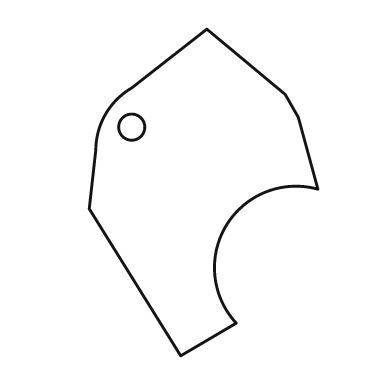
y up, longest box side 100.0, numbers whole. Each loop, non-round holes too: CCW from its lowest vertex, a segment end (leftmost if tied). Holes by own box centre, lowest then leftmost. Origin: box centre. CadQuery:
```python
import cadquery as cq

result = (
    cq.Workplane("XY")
    .moveTo(-7.0, -50.0)
    .lineTo(10.0, -40.0)
    .threePointArc((7.0, -10.0), (35.0, 1.0))
    .lineTo(29.0, 23.0)
    .lineTo(25.0, 30.0)
    .lineTo(1.0, 50.0)
    .lineTo(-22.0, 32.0)
    .threePointArc((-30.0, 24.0), (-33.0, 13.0))
    .lineTo(-35.0, -5.0)
    .close()
    .moveTo(-22.0, 20.0)
    .circle(4.0)
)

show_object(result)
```